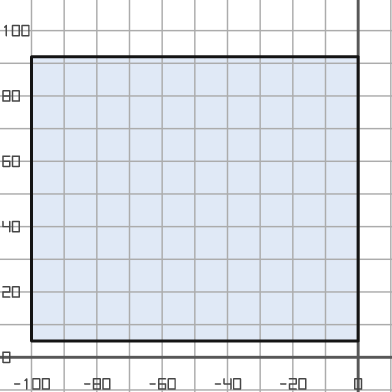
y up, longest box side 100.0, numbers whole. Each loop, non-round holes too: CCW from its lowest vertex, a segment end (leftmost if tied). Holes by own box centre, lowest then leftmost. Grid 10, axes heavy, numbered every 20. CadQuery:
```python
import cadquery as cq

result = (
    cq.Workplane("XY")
    .moveTo(-100.0, 5.0)
    .lineTo(0.0, 5.0)
    .lineTo(0.0, 92.0)
    .lineTo(-100.0, 92.0)
    .close()
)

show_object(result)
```